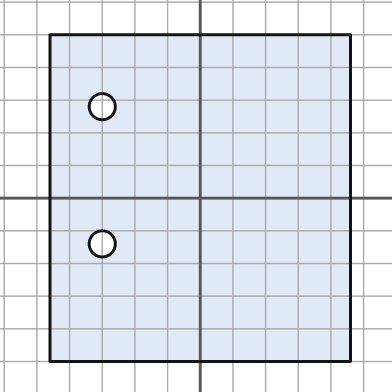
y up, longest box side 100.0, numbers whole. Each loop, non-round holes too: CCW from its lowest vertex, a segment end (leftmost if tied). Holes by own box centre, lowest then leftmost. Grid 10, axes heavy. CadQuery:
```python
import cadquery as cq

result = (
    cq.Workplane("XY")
    .moveTo(-46.0, -50.0)
    .lineTo(46.0, -50.0)
    .lineTo(46.0, 50.0)
    .lineTo(-46.0, 50.0)
    .close()
    .moveTo(-30.0, -14.0)
    .circle(4.0)
    .moveTo(-30.0, 28.0)
    .circle(4.0)
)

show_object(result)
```